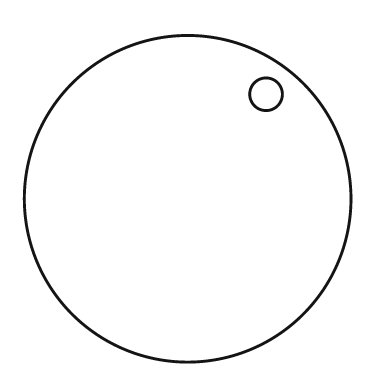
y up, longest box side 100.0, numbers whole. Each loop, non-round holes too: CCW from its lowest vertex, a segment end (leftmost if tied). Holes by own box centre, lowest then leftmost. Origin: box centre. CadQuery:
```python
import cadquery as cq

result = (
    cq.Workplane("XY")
    .moveTo(0.0, 0.0)
    .circle(50.0)
    .moveTo(24.0, 32.0)
    .circle(5.0)
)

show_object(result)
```